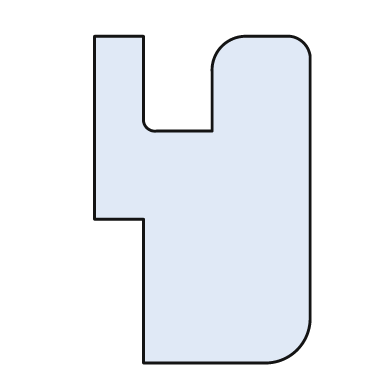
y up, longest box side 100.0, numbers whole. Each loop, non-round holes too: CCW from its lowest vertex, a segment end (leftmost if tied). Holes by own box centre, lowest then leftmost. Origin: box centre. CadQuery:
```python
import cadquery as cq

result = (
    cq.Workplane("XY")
    .moveTo(-18.0, -50.0)
    .lineTo(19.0, -50.0)
    .threePointArc((29.0, -46.0), (33.0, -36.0))
    .lineTo(33.0, 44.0)
    .threePointArc((31.0, 48.0), (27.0, 50.0))
    .lineTo(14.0, 50.0)
    .threePointArc((6.0, 47.0), (3.0, 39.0))
    .lineTo(3.0, 21.0)
    .lineTo(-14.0, 21.0)
    .threePointArc((-17.0, 22.0), (-18.0, 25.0))
    .lineTo(-18.0, 50.0)
    .lineTo(-33.0, 50.0)
    .lineTo(-33.0, -6.0)
    .lineTo(-18.0, -6.0)
    .close()
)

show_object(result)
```